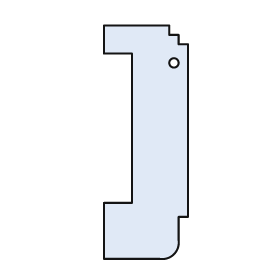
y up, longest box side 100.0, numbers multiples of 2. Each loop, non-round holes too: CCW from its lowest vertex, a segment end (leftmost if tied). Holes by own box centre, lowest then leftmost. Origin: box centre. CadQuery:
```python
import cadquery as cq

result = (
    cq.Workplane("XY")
    .moveTo(-18.0, -50.0)
    .lineTo(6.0, -50.0)
    .threePointArc((12.0, -48.0), (14.0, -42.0))
    .lineTo(14.0, -32.0)
    .lineTo(18.0, -32.0)
    .lineTo(18.0, 42.0)
    .lineTo(14.0, 42.0)
    .lineTo(14.0, 46.0)
    .lineTo(10.0, 46.0)
    .lineTo(10.0, 50.0)
    .lineTo(-18.0, 50.0)
    .lineTo(-18.0, 38.0)
    .lineTo(-6.0, 38.0)
    .lineTo(-6.0, -26.0)
    .lineTo(-18.0, -26.0)
    .close()
    .moveTo(12.0, 34.0)
    .circle(2.0)
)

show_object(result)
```